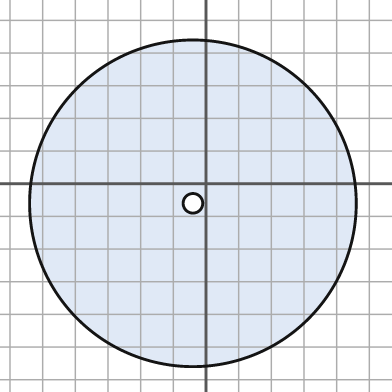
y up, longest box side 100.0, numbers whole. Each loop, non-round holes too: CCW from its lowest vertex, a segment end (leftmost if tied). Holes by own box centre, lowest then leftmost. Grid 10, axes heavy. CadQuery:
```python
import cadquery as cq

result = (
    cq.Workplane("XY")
    .moveTo(-4.0, -6.0)
    .circle(50.0)
    .moveTo(-4.0, -6.0)
    .circle(3.0)
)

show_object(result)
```